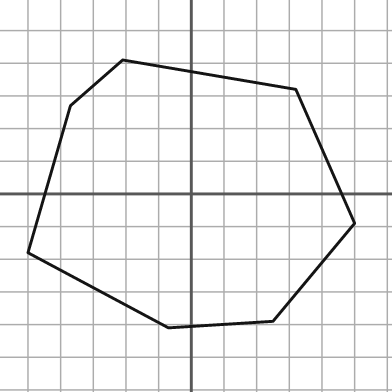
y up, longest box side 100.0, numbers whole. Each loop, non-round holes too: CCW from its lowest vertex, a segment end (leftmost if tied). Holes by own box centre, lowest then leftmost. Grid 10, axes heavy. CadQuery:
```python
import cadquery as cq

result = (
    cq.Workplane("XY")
    .moveTo(-7.0, -41.0)
    .lineTo(25.0, -39.0)
    .lineTo(50.0, -9.0)
    .lineTo(32.0, 32.0)
    .lineTo(-21.0, 41.0)
    .lineTo(-37.0, 27.0)
    .lineTo(-50.0, -18.0)
    .close()
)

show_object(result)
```